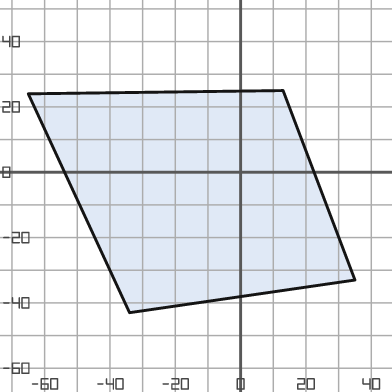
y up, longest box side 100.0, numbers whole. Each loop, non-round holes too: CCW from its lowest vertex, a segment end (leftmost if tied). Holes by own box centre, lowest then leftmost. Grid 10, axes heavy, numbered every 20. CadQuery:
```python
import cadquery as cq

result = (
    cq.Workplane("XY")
    .moveTo(-34.0, -43.0)
    .lineTo(35.0, -33.0)
    .lineTo(13.0, 25.0)
    .lineTo(-65.0, 24.0)
    .close()
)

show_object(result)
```